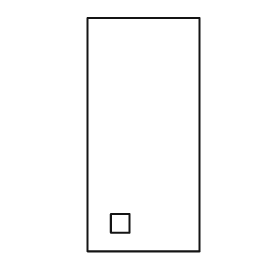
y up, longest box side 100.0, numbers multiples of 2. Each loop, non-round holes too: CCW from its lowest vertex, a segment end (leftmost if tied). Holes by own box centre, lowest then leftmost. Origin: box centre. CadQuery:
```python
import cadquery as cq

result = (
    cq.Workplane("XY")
    .moveTo(-24.0, -50.0)
    .lineTo(24.0, -50.0)
    .lineTo(24.0, 50.0)
    .lineTo(-24.0, 50.0)
    .close()
    .moveTo(-14.0, -42.0)
    .lineTo(-6.0, -42.0)
    .lineTo(-6.0, -34.0)
    .lineTo(-14.0, -34.0)
    .close()
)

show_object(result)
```